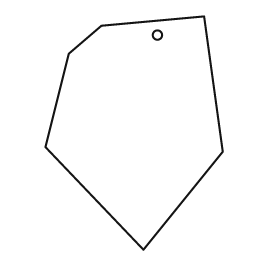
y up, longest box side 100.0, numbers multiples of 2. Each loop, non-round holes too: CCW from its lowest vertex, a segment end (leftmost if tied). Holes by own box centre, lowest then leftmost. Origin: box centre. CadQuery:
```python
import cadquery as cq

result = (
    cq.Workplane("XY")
    .moveTo(4.0, -50.0)
    .lineTo(38.0, -8.0)
    .lineTo(30.0, 50.0)
    .lineTo(-14.0, 46.0)
    .lineTo(-28.0, 34.0)
    .lineTo(-38.0, -6.0)
    .close()
    .moveTo(10.0, 42.0)
    .circle(2.0)
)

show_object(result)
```